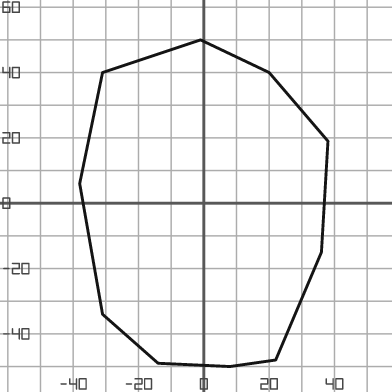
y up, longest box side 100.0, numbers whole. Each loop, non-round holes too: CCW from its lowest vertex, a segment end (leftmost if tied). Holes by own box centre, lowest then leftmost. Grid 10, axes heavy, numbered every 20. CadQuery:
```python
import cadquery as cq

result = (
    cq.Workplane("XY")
    .moveTo(8.0, -50.0)
    .lineTo(22.0, -48.0)
    .lineTo(36.0, -15.0)
    .lineTo(38.0, 19.0)
    .lineTo(20.0, 40.0)
    .lineTo(-1.0, 50.0)
    .lineTo(-31.0, 40.0)
    .lineTo(-38.0, 6.0)
    .lineTo(-31.0, -34.0)
    .lineTo(-14.0, -49.0)
    .close()
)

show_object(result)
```